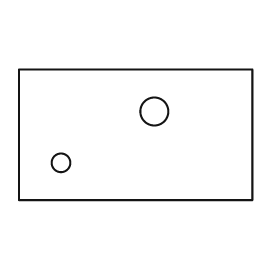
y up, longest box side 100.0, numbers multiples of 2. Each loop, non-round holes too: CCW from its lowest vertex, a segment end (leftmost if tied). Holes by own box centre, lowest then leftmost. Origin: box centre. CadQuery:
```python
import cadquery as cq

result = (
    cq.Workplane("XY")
    .moveTo(-50.0, -28.0)
    .lineTo(50.0, -28.0)
    .lineTo(50.0, 28.0)
    .lineTo(-50.0, 28.0)
    .close()
    .moveTo(-32.0, -12.0)
    .circle(4.0)
    .moveTo(8.0, 10.0)
    .circle(6.0)
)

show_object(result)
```